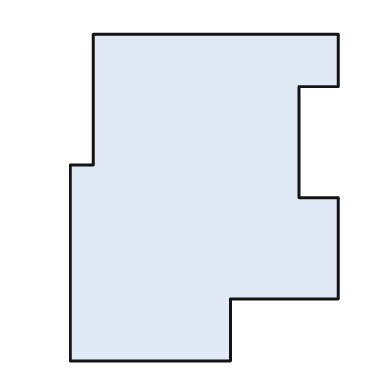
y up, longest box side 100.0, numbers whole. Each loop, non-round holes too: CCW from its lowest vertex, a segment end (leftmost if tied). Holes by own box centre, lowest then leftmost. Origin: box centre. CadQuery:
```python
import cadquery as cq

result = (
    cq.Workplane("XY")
    .moveTo(-41.0, -50.0)
    .lineTo(8.0, -50.0)
    .lineTo(8.0, -31.0)
    .lineTo(41.0, -31.0)
    .lineTo(41.0, 0.0)
    .lineTo(29.0, 0.0)
    .lineTo(29.0, 34.0)
    .lineTo(41.0, 34.0)
    .lineTo(41.0, 50.0)
    .lineTo(-34.0, 50.0)
    .lineTo(-34.0, 10.0)
    .lineTo(-41.0, 10.0)
    .close()
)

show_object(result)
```